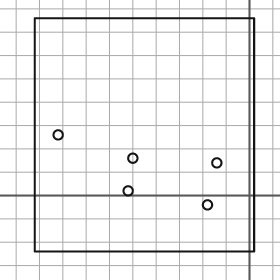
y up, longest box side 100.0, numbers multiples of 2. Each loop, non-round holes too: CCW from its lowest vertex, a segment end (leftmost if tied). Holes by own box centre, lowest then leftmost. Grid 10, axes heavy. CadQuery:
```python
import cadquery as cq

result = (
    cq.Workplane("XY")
    .moveTo(-92.0, -24.0)
    .lineTo(2.0, -24.0)
    .lineTo(2.0, 76.0)
    .lineTo(-92.0, 76.0)
    .close()
    .moveTo(-18.0, -4.0)
    .circle(2.0)
    .moveTo(-52.0, 2.0)
    .circle(2.0)
    .moveTo(-14.0, 14.0)
    .circle(2.0)
    .moveTo(-50.0, 16.0)
    .circle(2.0)
    .moveTo(-82.0, 26.0)
    .circle(2.0)
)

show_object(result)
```